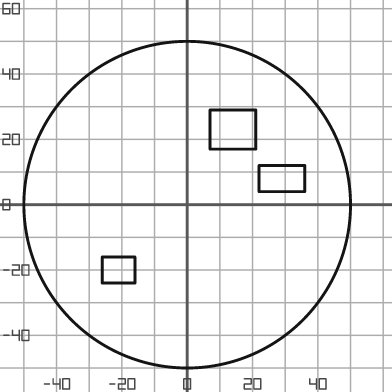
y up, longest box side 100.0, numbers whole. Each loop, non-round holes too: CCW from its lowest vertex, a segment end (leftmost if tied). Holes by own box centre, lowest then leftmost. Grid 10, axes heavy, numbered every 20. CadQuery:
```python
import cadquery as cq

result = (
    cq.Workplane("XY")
    .moveTo(0.0, 0.0)
    .circle(50.0)
    .moveTo(-26.0, -24.0)
    .lineTo(-16.0, -24.0)
    .lineTo(-16.0, -16.0)
    .lineTo(-26.0, -16.0)
    .close()
    .moveTo(22.0, 4.0)
    .lineTo(36.0, 4.0)
    .lineTo(36.0, 12.0)
    .lineTo(22.0, 12.0)
    .close()
    .moveTo(7.0, 17.0)
    .lineTo(21.0, 17.0)
    .lineTo(21.0, 29.0)
    .lineTo(7.0, 29.0)
    .close()
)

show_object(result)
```